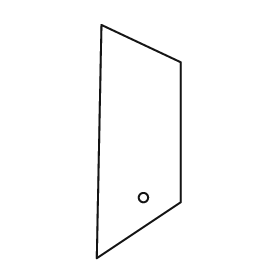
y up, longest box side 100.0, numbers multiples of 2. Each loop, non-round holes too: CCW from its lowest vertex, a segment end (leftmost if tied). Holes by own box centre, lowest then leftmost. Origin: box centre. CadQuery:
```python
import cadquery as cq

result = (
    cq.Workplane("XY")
    .moveTo(-18.0, -50.0)
    .lineTo(18.0, -26.0)
    .lineTo(18.0, 34.0)
    .lineTo(-16.0, 50.0)
    .close()
    .moveTo(2.0, -24.0)
    .circle(2.0)
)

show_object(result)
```